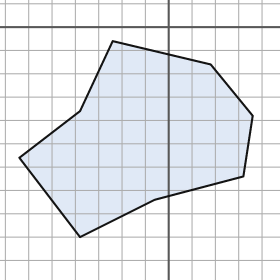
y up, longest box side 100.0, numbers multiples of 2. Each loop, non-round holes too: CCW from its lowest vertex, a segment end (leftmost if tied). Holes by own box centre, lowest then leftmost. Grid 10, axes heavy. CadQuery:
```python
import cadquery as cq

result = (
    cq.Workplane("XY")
    .moveTo(-38.0, -90.0)
    .lineTo(-6.0, -74.0)
    .lineTo(32.0, -64.0)
    .lineTo(36.0, -38.0)
    .lineTo(18.0, -16.0)
    .lineTo(-24.0, -6.0)
    .lineTo(-38.0, -36.0)
    .lineTo(-64.0, -56.0)
    .close()
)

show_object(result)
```